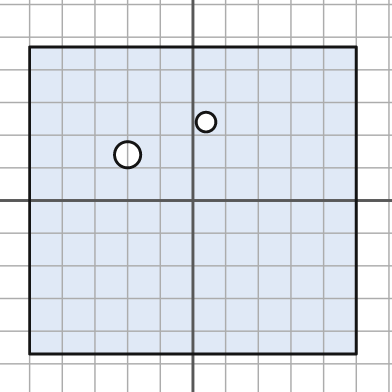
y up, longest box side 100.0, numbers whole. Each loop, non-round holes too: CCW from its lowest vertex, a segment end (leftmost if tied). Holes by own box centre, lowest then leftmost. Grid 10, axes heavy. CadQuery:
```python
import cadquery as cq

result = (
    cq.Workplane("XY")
    .moveTo(-50.0, -47.0)
    .lineTo(50.0, -47.0)
    .lineTo(50.0, 47.0)
    .lineTo(-50.0, 47.0)
    .close()
    .moveTo(-20.0, 14.0)
    .circle(4.0)
    .moveTo(4.0, 24.0)
    .circle(3.0)
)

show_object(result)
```